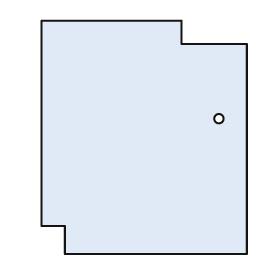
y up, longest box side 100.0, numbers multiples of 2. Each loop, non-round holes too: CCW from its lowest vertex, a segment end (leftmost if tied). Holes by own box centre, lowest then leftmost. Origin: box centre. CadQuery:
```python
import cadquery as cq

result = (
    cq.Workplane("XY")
    .moveTo(-34.0, -50.0)
    .lineTo(44.0, -50.0)
    .lineTo(44.0, 40.0)
    .lineTo(16.0, 40.0)
    .lineTo(16.0, 50.0)
    .lineTo(-44.0, 50.0)
    .lineTo(-44.0, -38.0)
    .lineTo(-34.0, -38.0)
    .close()
    .moveTo(32.0, 8.0)
    .circle(2.0)
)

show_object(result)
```